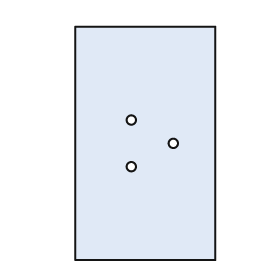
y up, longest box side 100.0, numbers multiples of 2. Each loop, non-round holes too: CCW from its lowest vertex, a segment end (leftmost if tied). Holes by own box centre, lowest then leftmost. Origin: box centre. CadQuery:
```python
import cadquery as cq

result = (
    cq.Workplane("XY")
    .moveTo(-30.0, -50.0)
    .lineTo(30.0, -50.0)
    .lineTo(30.0, 50.0)
    .lineTo(-30.0, 50.0)
    .close()
    .moveTo(-6.0, -10.0)
    .circle(2.0)
    .moveTo(12.0, 0.0)
    .circle(2.0)
    .moveTo(-6.0, 10.0)
    .circle(2.0)
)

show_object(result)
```